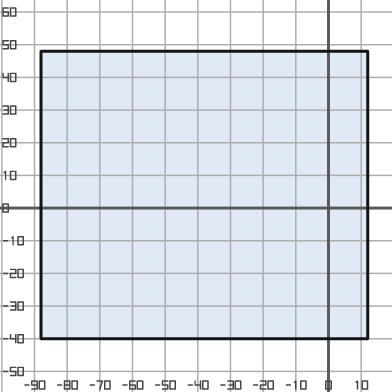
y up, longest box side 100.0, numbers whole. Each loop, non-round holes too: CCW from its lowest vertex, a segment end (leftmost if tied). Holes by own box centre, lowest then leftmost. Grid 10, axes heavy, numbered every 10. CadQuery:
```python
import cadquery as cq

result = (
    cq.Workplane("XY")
    .moveTo(-88.0, -40.0)
    .lineTo(12.0, -40.0)
    .lineTo(12.0, 48.0)
    .lineTo(-88.0, 48.0)
    .close()
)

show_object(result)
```